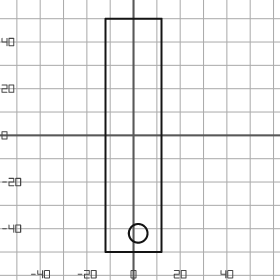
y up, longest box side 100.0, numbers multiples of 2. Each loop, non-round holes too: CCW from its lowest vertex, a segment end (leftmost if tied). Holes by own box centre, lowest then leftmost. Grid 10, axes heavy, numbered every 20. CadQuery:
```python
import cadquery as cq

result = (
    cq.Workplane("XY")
    .moveTo(-12.0, -50.0)
    .lineTo(12.0, -50.0)
    .lineTo(12.0, 50.0)
    .lineTo(-12.0, 50.0)
    .close()
    .moveTo(2.0, -42.0)
    .circle(4.0)
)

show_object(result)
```